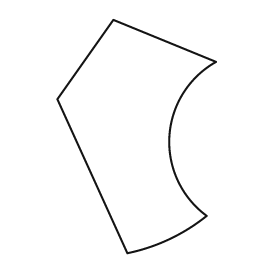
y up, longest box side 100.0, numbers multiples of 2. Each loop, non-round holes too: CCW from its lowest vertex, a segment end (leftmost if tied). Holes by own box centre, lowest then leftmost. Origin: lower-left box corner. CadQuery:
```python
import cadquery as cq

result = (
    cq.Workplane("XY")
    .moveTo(30.0, 0.0)
    .threePointArc((48.0, 6.0), (64.0, 16.0))
    .threePointArc((48.0, 50.0), (68.0, 82.0))
    .lineTo(24.0, 100.0)
    .lineTo(0.0, 66.0)
    .close()
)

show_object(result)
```